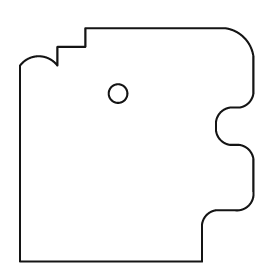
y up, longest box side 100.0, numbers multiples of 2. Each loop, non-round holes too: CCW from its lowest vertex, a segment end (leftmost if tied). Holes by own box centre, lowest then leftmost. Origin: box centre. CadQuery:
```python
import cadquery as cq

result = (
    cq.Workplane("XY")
    .moveTo(-50.0, -50.0)
    .lineTo(28.0, -50.0)
    .lineTo(28.0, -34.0)
    .threePointArc((30.0, -30.0), (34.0, -28.0))
    .lineTo(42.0, -28.0)
    .threePointArc((48.0, -26.0), (50.0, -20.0))
    .lineTo(50.0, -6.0)
    .threePointArc((48.0, -2.0), (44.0, 0.0))
    .lineTo(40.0, 0.0)
    .threePointArc((36.0, 2.0), (34.0, 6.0))
    .lineTo(34.0, 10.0)
    .threePointArc((36.0, 14.0), (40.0, 16.0))
    .lineTo(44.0, 16.0)
    .threePointArc((48.0, 18.0), (50.0, 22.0))
    .lineTo(50.0, 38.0)
    .threePointArc((46.0, 46.0), (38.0, 50.0))
    .lineTo(-22.0, 50.0)
    .lineTo(-22.0, 42.0)
    .lineTo(-34.0, 42.0)
    .lineTo(-34.0, 34.0)
    .threePointArc((-42.0, 38.0), (-50.0, 34.0))
    .close()
    .moveTo(-8.0, 22.0)
    .circle(4.0)
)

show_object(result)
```